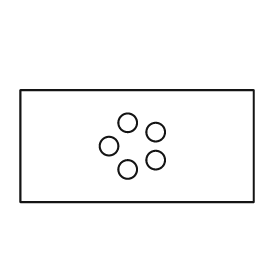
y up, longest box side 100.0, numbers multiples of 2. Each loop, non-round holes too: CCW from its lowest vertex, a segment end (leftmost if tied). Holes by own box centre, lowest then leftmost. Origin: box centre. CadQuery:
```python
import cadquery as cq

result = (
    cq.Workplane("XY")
    .moveTo(-50.0, -24.0)
    .lineTo(50.0, -24.0)
    .lineTo(50.0, 24.0)
    .lineTo(-50.0, 24.0)
    .close()
    .moveTo(-4.0, -10.0)
    .circle(4.0)
    .moveTo(8.0, -6.0)
    .circle(4.0)
    .moveTo(-12.0, 0.0)
    .circle(4.0)
    .moveTo(8.0, 6.0)
    .circle(4.0)
    .moveTo(-4.0, 10.0)
    .circle(4.0)
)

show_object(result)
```